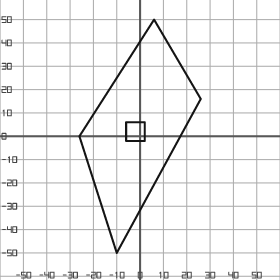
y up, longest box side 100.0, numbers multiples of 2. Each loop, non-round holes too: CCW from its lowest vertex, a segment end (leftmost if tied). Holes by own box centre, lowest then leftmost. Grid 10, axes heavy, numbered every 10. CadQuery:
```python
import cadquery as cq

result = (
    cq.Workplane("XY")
    .moveTo(-10.0, -50.0)
    .lineTo(26.0, 16.0)
    .lineTo(6.0, 50.0)
    .lineTo(-26.0, 0.0)
    .close()
    .moveTo(-6.0, -2.0)
    .lineTo(2.0, -2.0)
    .lineTo(2.0, 6.0)
    .lineTo(-6.0, 6.0)
    .close()
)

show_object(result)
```